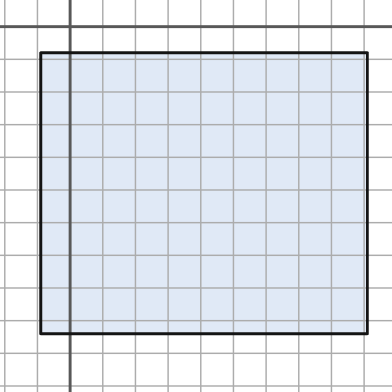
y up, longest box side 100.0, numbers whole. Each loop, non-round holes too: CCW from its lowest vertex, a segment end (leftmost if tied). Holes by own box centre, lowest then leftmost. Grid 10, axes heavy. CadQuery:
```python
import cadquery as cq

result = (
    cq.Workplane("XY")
    .moveTo(-9.0, -94.0)
    .lineTo(91.0, -94.0)
    .lineTo(91.0, -8.0)
    .lineTo(-9.0, -8.0)
    .close()
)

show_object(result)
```